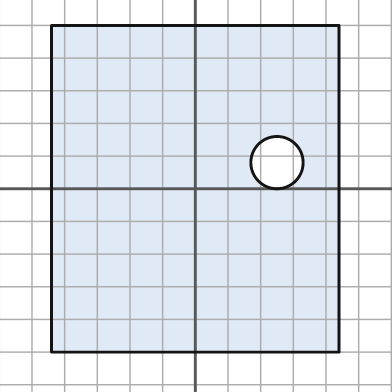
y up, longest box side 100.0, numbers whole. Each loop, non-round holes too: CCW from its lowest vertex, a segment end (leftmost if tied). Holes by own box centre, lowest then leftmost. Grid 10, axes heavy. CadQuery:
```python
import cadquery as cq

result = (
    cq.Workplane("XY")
    .moveTo(-44.0, -50.0)
    .lineTo(44.0, -50.0)
    .lineTo(44.0, 50.0)
    .lineTo(-44.0, 50.0)
    .close()
    .moveTo(25.0, 8.0)
    .circle(8.0)
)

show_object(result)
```